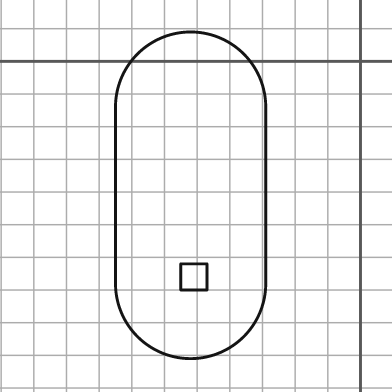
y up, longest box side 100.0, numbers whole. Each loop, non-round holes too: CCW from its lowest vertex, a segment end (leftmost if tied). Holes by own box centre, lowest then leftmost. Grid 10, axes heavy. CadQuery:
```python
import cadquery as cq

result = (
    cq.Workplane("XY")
    .moveTo(-75.0, -68.0)
    .threePointArc((-52.0, -91.0), (-29.0, -68.0))
    .lineTo(-29.0, -14.0)
    .threePointArc((-52.0, 9.0), (-75.0, -14.0))
    .close()
    .moveTo(-55.0, -70.0)
    .lineTo(-47.0, -70.0)
    .lineTo(-47.0, -62.0)
    .lineTo(-55.0, -62.0)
    .close()
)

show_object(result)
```